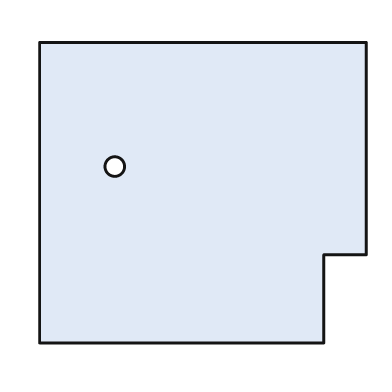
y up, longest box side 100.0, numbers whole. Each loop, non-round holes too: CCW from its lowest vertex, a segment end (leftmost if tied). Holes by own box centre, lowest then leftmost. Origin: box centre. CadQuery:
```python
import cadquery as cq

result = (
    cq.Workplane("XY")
    .moveTo(-50.0, -46.0)
    .lineTo(37.0, -46.0)
    .lineTo(37.0, -19.0)
    .lineTo(50.0, -19.0)
    .lineTo(50.0, 46.0)
    .lineTo(-50.0, 46.0)
    .close()
    .moveTo(-27.0, 8.0)
    .circle(3.0)
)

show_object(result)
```